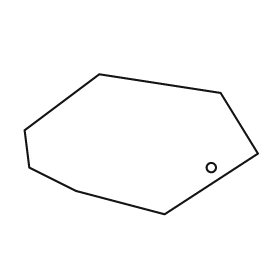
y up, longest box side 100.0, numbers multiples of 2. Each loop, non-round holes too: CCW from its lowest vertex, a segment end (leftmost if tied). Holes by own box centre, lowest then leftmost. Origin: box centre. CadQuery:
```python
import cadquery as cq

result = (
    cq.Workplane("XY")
    .moveTo(10.0, -30.0)
    .lineTo(50.0, -4.0)
    .lineTo(34.0, 22.0)
    .lineTo(-18.0, 30.0)
    .lineTo(-50.0, 6.0)
    .lineTo(-48.0, -10.0)
    .lineTo(-28.0, -20.0)
    .close()
    .moveTo(30.0, -10.0)
    .circle(2.0)
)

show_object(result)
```